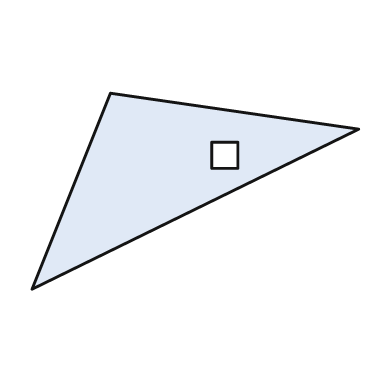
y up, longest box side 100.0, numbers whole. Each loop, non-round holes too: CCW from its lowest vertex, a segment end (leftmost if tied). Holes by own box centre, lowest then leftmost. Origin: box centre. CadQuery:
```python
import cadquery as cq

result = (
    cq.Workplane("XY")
    .moveTo(-50.0, -30.0)
    .lineTo(50.0, 19.0)
    .lineTo(-26.0, 30.0)
    .close()
    .moveTo(5.0, 7.0)
    .lineTo(13.0, 7.0)
    .lineTo(13.0, 15.0)
    .lineTo(5.0, 15.0)
    .close()
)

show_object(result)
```